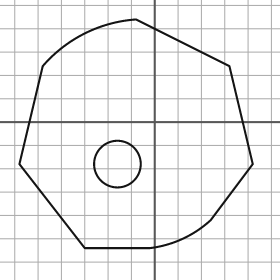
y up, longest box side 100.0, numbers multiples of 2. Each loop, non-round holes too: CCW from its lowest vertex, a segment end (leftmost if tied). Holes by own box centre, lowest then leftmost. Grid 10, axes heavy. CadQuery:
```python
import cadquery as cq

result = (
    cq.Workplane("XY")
    .moveTo(-30.0, -54.0)
    .lineTo(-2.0, -54.0)
    .threePointArc((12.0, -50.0), (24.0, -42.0))
    .lineTo(42.0, -18.0)
    .lineTo(32.0, 24.0)
    .lineTo(-8.0, 44.0)
    .threePointArc((-30.0, 38.0), (-48.0, 24.0))
    .lineTo(-58.0, -18.0)
    .close()
    .moveTo(-16.0, -18.0)
    .circle(10.0)
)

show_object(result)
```